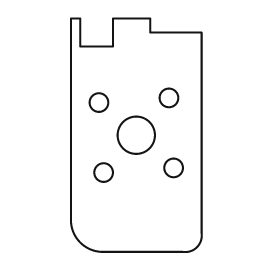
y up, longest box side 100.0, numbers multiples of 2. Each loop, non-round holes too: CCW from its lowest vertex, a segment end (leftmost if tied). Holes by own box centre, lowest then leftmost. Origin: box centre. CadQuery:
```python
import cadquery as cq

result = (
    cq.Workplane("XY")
    .moveTo(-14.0, -50.0)
    .lineTo(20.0, -50.0)
    .threePointArc((26.0, -48.0), (28.0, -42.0))
    .lineTo(28.0, 44.0)
    .lineTo(6.0, 44.0)
    .lineTo(6.0, 50.0)
    .lineTo(-10.0, 50.0)
    .lineTo(-10.0, 38.0)
    .lineTo(-24.0, 38.0)
    .lineTo(-24.0, 50.0)
    .lineTo(-28.0, 50.0)
    .lineTo(-28.0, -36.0)
    .threePointArc((-24.0, -46.0), (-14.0, -50.0))
    .close()
    .moveTo(-14.0, -16.0)
    .circle(4.0)
    .moveTo(16.0, -14.0)
    .circle(4.0)
    .moveTo(0.0, 0.0)
    .circle(8.0)
    .moveTo(-16.0, 14.0)
    .circle(4.0)
    .moveTo(14.0, 16.0)
    .circle(4.0)
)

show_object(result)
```